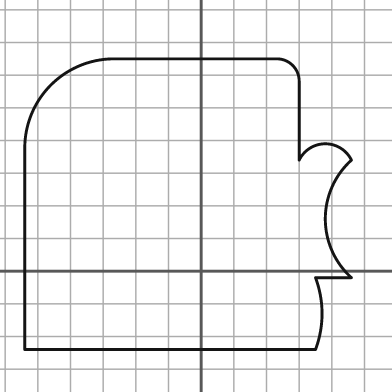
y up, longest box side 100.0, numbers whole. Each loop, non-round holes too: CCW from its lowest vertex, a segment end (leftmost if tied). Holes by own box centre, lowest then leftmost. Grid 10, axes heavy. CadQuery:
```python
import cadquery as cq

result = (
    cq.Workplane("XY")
    .moveTo(-54.0, -24.0)
    .lineTo(35.0, -24.0)
    .threePointArc((37.0, -13.0), (35.0, -2.0))
    .lineTo(46.0, -2.0)
    .threePointArc((38.0, 16.0), (46.0, 34.0))
    .threePointArc((38.0, 39.0), (30.0, 34.0))
    .lineTo(30.0, 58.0)
    .threePointArc((28.0, 63.0), (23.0, 65.0))
    .lineTo(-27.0, 65.0)
    .threePointArc((-46.0, 57.0), (-54.0, 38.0))
    .close()
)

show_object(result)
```